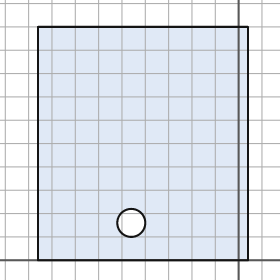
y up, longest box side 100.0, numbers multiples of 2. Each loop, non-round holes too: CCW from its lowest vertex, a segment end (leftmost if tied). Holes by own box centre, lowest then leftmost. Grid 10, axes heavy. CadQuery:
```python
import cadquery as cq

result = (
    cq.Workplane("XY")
    .moveTo(-86.0, 0.0)
    .lineTo(4.0, 0.0)
    .lineTo(4.0, 100.0)
    .lineTo(-86.0, 100.0)
    .close()
    .moveTo(-46.0, 16.0)
    .circle(6.0)
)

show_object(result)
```